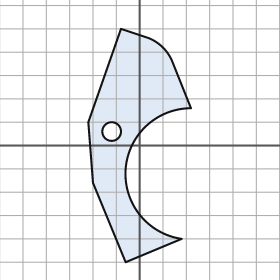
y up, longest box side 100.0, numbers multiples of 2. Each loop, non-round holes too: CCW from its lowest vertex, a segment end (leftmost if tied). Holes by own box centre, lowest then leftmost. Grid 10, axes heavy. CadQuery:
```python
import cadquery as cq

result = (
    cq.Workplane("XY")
    .moveTo(-6.0, -50.0)
    .lineTo(18.0, -40.0)
    .threePointArc((-6.0, -10.0), (22.0, 16.0))
    .lineTo(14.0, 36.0)
    .threePointArc((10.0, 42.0), (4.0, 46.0))
    .lineTo(-8.0, 50.0)
    .lineTo(-22.0, 10.0)
    .lineTo(-20.0, -16.0)
    .close()
    .moveTo(-12.0, 6.0)
    .circle(4.0)
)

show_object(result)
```